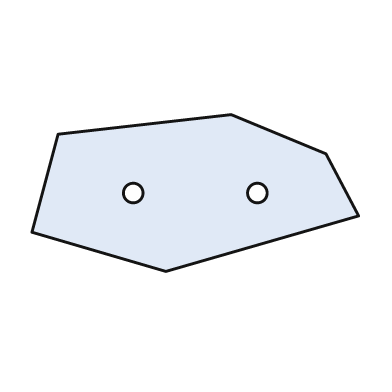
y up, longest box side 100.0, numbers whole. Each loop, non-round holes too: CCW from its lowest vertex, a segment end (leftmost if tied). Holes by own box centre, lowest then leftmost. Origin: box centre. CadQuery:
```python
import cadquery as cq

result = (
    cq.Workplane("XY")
    .moveTo(-9.0, -24.0)
    .lineTo(50.0, -7.0)
    .lineTo(40.0, 12.0)
    .lineTo(11.0, 24.0)
    .lineTo(-42.0, 18.0)
    .lineTo(-50.0, -12.0)
    .close()
    .moveTo(-19.0, 0.0)
    .circle(3.0)
    .moveTo(19.0, 0.0)
    .circle(3.0)
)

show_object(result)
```